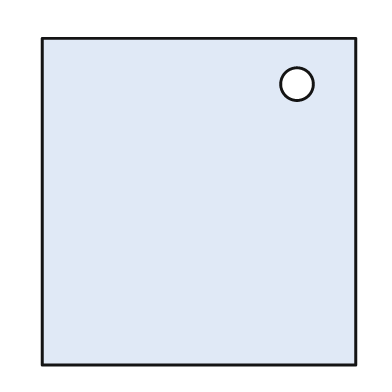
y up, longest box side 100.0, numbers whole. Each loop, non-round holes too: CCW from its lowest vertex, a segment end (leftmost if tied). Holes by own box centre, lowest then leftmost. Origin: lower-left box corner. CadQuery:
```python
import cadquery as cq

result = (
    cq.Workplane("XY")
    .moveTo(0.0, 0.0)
    .lineTo(96.0, 0.0)
    .lineTo(96.0, 100.0)
    .lineTo(0.0, 100.0)
    .close()
    .moveTo(78.0, 86.0)
    .circle(5.0)
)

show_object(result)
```